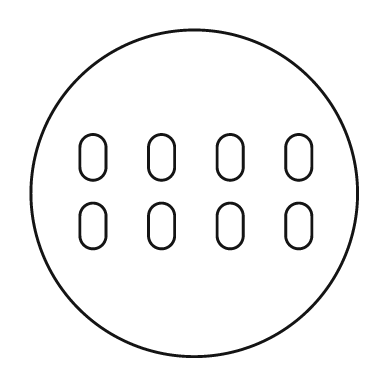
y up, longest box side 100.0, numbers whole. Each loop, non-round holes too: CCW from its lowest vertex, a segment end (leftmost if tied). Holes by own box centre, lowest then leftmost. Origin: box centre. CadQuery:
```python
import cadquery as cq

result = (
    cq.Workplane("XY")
    .moveTo(0.0, 0.0)
    .circle(50.0)
    .moveTo(-35.0, -13.0)
    .threePointArc((-31.0, -17.0), (-27.0, -13.0))
    .lineTo(-27.0, -7.0)
    .threePointArc((-31.0, -3.0), (-35.0, -7.0))
    .close()
    .moveTo(-14.0, -13.0)
    .threePointArc((-10.0, -17.0), (-6.0, -13.0))
    .lineTo(-6.0, -7.0)
    .threePointArc((-10.0, -3.0), (-14.0, -7.0))
    .close()
    .moveTo(7.0, -13.0)
    .threePointArc((11.0, -17.0), (15.0, -13.0))
    .lineTo(15.0, -7.0)
    .threePointArc((11.0, -3.0), (7.0, -7.0))
    .close()
    .moveTo(28.0, -13.0)
    .threePointArc((32.0, -17.0), (36.0, -13.0))
    .lineTo(36.0, -7.0)
    .threePointArc((32.0, -3.0), (28.0, -7.0))
    .close()
    .moveTo(-35.0, 8.0)
    .threePointArc((-31.0, 4.0), (-27.0, 8.0))
    .lineTo(-27.0, 14.0)
    .threePointArc((-31.0, 18.0), (-35.0, 14.0))
    .close()
    .moveTo(-14.0, 8.0)
    .threePointArc((-10.0, 4.0), (-6.0, 8.0))
    .lineTo(-6.0, 14.0)
    .threePointArc((-10.0, 18.0), (-14.0, 14.0))
    .close()
    .moveTo(7.0, 8.0)
    .threePointArc((11.0, 4.0), (15.0, 8.0))
    .lineTo(15.0, 14.0)
    .threePointArc((11.0, 18.0), (7.0, 14.0))
    .close()
    .moveTo(28.0, 8.0)
    .threePointArc((32.0, 4.0), (36.0, 8.0))
    .lineTo(36.0, 14.0)
    .threePointArc((32.0, 18.0), (28.0, 14.0))
    .close()
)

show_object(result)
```